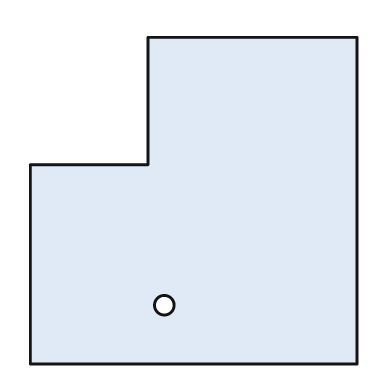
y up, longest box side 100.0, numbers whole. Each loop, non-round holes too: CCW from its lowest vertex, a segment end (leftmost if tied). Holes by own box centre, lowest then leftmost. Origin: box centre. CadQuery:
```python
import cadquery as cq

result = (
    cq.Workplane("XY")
    .moveTo(-50.0, -50.0)
    .lineTo(50.0, -50.0)
    .lineTo(50.0, 50.0)
    .lineTo(-14.0, 50.0)
    .lineTo(-14.0, 11.0)
    .lineTo(-50.0, 11.0)
    .close()
    .moveTo(-9.0, -32.0)
    .circle(3.0)
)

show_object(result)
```